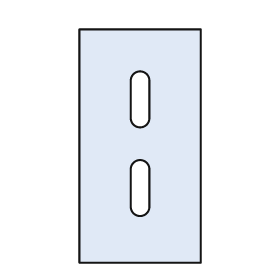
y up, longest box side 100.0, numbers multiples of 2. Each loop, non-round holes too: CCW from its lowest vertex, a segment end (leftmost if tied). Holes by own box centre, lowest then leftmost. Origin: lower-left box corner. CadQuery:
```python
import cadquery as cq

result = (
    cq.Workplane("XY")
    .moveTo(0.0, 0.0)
    .lineTo(52.0, 0.0)
    .lineTo(52.0, 100.0)
    .lineTo(0.0, 100.0)
    .close()
    .moveTo(22.0, 24.0)
    .threePointArc((26.0, 20.0), (30.0, 24.0))
    .lineTo(30.0, 40.0)
    .threePointArc((26.0, 44.0), (22.0, 40.0))
    .close()
    .moveTo(22.0, 62.0)
    .threePointArc((26.0, 58.0), (30.0, 62.0))
    .lineTo(30.0, 78.0)
    .threePointArc((26.0, 82.0), (22.0, 78.0))
    .close()
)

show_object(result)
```